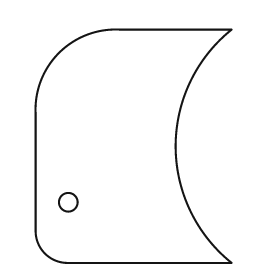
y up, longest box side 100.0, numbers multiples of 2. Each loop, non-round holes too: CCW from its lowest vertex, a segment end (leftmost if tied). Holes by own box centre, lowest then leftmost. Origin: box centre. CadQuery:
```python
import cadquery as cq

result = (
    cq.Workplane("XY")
    .moveTo(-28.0, -50.0)
    .lineTo(42.0, -50.0)
    .threePointArc((18.0, 0.0), (42.0, 50.0))
    .lineTo(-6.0, 50.0)
    .threePointArc((-32.0, 40.0), (-42.0, 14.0))
    .lineTo(-42.0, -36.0)
    .threePointArc((-38.0, -46.0), (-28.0, -50.0))
    .close()
    .moveTo(-28.0, -24.0)
    .circle(4.0)
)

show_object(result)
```